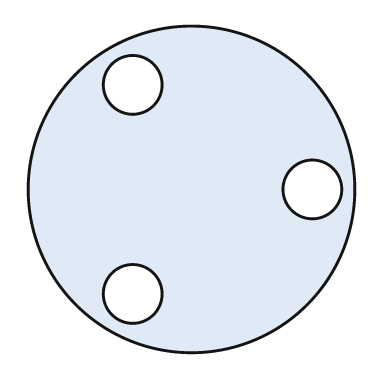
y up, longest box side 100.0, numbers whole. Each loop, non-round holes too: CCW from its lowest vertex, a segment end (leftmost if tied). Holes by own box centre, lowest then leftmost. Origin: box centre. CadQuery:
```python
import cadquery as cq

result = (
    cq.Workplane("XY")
    .moveTo(0.0, 0.0)
    .circle(50.0)
    .moveTo(-18.0, -32.0)
    .circle(9.0)
    .moveTo(37.0, 0.0)
    .circle(9.0)
    .moveTo(-18.0, 32.0)
    .circle(9.0)
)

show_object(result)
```